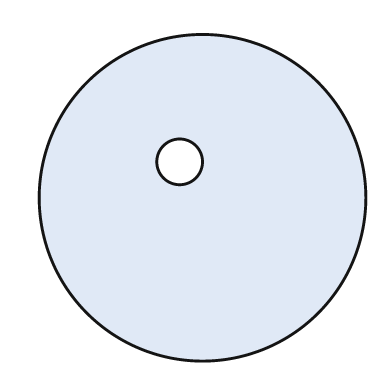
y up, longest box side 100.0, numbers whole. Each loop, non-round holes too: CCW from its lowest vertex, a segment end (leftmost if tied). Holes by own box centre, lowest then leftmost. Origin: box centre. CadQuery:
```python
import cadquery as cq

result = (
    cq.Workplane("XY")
    .moveTo(0.0, 0.0)
    .circle(50.0)
    .moveTo(-7.0, 11.0)
    .circle(7.0)
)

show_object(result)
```